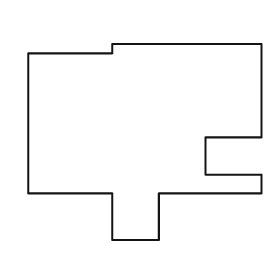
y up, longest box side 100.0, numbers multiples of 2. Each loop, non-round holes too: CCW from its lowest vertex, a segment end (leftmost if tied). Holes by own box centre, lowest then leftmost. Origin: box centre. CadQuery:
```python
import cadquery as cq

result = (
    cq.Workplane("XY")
    .moveTo(-14.0, -42.0)
    .lineTo(6.0, -42.0)
    .lineTo(6.0, -22.0)
    .lineTo(50.0, -22.0)
    .lineTo(50.0, -14.0)
    .lineTo(26.0, -14.0)
    .lineTo(26.0, 2.0)
    .lineTo(50.0, 2.0)
    .lineTo(50.0, 42.0)
    .lineTo(-14.0, 42.0)
    .lineTo(-14.0, 38.0)
    .lineTo(-50.0, 38.0)
    .lineTo(-50.0, -22.0)
    .lineTo(-14.0, -22.0)
    .close()
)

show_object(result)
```